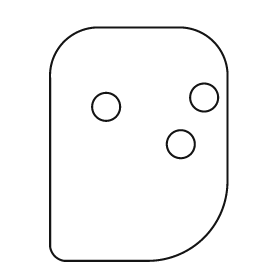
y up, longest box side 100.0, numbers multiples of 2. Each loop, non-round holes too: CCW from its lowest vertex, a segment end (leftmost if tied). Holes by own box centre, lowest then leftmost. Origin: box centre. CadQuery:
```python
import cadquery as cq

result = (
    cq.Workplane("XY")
    .moveTo(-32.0, -50.0)
    .lineTo(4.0, -50.0)
    .threePointArc((28.0, -40.0), (38.0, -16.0))
    .lineTo(38.0, 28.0)
    .threePointArc((32.0, 44.0), (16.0, 50.0))
    .lineTo(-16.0, 50.0)
    .threePointArc((-32.0, 44.0), (-38.0, 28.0))
    .lineTo(-38.0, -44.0)
    .threePointArc((-36.0, -48.0), (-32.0, -50.0))
    .close()
    .moveTo(18.0, 0.0)
    .circle(6.0)
    .moveTo(-14.0, 16.0)
    .circle(6.0)
    .moveTo(28.0, 20.0)
    .circle(6.0)
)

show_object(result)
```